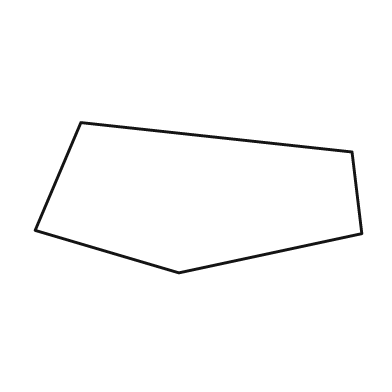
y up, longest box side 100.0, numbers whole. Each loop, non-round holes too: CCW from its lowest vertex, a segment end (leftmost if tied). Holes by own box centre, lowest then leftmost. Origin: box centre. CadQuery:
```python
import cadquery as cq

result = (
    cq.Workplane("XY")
    .moveTo(-6.0, -23.0)
    .lineTo(50.0, -11.0)
    .lineTo(47.0, 14.0)
    .lineTo(-36.0, 23.0)
    .lineTo(-50.0, -10.0)
    .close()
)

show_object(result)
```